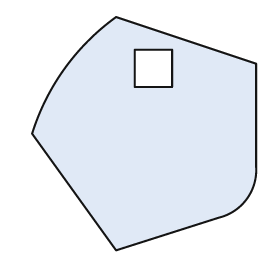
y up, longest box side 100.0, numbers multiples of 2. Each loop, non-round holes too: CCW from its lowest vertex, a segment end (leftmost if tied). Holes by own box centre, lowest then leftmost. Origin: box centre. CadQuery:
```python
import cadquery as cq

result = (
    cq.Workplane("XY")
    .moveTo(-12.0, -50.0)
    .lineTo(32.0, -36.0)
    .threePointArc((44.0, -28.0), (48.0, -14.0))
    .lineTo(48.0, 30.0)
    .lineTo(-12.0, 50.0)
    .threePointArc((-34.0, 28.0), (-48.0, 0.0))
    .close()
    .moveTo(-4.0, 20.0)
    .lineTo(12.0, 20.0)
    .lineTo(12.0, 36.0)
    .lineTo(-4.0, 36.0)
    .close()
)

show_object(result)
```